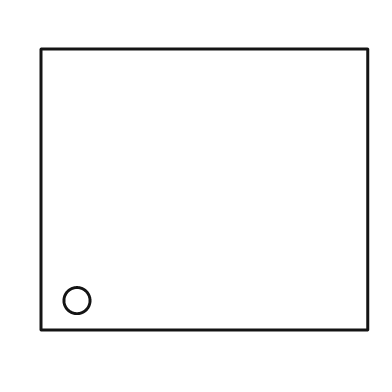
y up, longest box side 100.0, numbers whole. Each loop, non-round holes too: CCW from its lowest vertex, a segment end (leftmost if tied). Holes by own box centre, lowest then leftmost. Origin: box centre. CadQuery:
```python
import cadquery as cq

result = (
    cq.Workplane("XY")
    .moveTo(-50.0, -43.0)
    .lineTo(50.0, -43.0)
    .lineTo(50.0, 43.0)
    .lineTo(-50.0, 43.0)
    .close()
    .moveTo(-39.0, -34.0)
    .circle(4.0)
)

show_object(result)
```